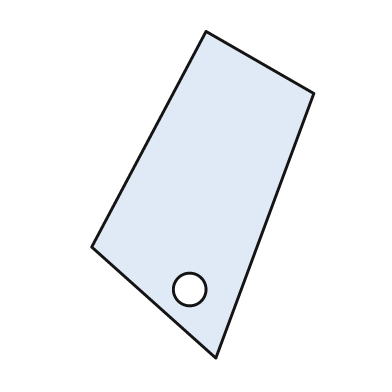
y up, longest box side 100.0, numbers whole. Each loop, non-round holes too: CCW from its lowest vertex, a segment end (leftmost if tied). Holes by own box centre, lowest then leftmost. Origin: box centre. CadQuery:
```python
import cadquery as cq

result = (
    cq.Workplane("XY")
    .moveTo(4.0, -50.0)
    .lineTo(34.0, 31.0)
    .lineTo(1.0, 50.0)
    .lineTo(-34.0, -16.0)
    .close()
    .moveTo(-4.0, -29.0)
    .circle(5.0)
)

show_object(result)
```